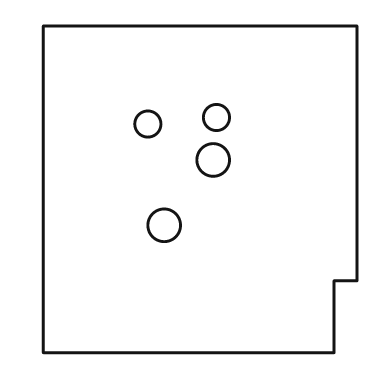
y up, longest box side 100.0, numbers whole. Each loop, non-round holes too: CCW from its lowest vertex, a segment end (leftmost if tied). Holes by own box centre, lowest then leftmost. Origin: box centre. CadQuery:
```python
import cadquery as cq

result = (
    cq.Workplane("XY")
    .moveTo(-48.0, -50.0)
    .lineTo(41.0, -50.0)
    .lineTo(41.0, -28.0)
    .lineTo(48.0, -28.0)
    .lineTo(48.0, 50.0)
    .lineTo(-48.0, 50.0)
    .close()
    .moveTo(-11.0, -11.0)
    .circle(5.0)
    .moveTo(4.0, 9.0)
    .circle(5.0)
    .moveTo(-16.0, 20.0)
    .circle(4.0)
    .moveTo(5.0, 22.0)
    .circle(4.0)
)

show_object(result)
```